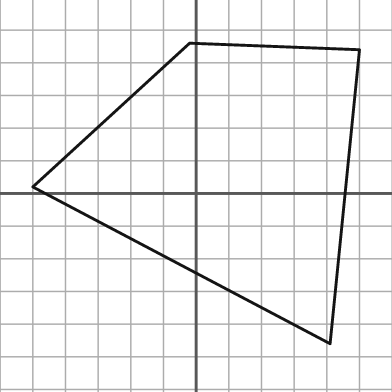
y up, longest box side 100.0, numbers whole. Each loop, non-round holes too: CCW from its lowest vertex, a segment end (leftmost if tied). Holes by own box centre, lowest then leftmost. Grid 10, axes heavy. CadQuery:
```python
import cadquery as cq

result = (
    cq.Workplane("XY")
    .moveTo(41.0, -46.0)
    .lineTo(50.0, 44.0)
    .lineTo(-2.0, 46.0)
    .lineTo(-50.0, 2.0)
    .close()
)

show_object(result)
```